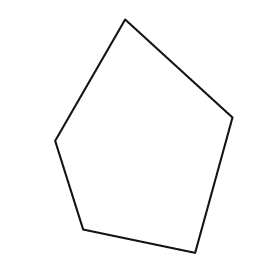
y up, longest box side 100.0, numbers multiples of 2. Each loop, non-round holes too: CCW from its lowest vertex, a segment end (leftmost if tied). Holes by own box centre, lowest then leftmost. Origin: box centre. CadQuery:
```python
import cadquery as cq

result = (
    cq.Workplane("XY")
    .moveTo(22.0, -50.0)
    .lineTo(38.0, 8.0)
    .lineTo(-8.0, 50.0)
    .lineTo(-38.0, -2.0)
    .lineTo(-26.0, -40.0)
    .close()
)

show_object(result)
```